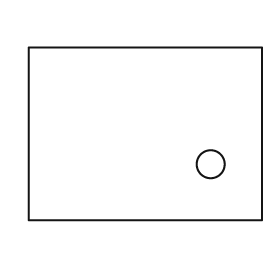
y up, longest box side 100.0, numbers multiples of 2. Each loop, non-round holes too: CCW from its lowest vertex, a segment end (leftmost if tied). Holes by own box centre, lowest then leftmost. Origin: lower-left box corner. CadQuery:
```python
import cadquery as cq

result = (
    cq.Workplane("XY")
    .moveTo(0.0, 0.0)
    .lineTo(100.0, 0.0)
    .lineTo(100.0, 74.0)
    .lineTo(0.0, 74.0)
    .close()
    .moveTo(78.0, 24.0)
    .circle(6.0)
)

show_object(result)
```